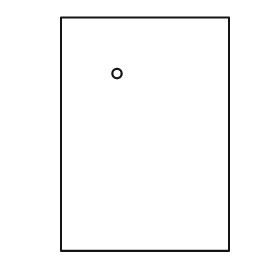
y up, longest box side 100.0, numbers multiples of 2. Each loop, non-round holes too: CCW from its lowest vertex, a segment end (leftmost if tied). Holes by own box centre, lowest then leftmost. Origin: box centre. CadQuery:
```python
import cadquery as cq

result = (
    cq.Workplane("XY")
    .moveTo(-36.0, -50.0)
    .lineTo(36.0, -50.0)
    .lineTo(36.0, 50.0)
    .lineTo(-36.0, 50.0)
    .close()
    .moveTo(-12.0, 26.0)
    .circle(2.0)
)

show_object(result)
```